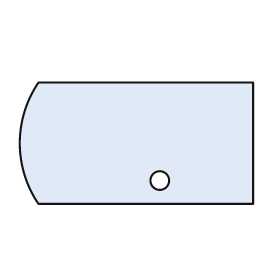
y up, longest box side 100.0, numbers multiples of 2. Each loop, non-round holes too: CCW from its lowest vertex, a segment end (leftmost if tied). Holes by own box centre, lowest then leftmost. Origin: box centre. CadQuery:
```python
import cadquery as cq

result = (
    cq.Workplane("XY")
    .moveTo(-42.0, -26.0)
    .lineTo(50.0, -26.0)
    .lineTo(50.0, 26.0)
    .lineTo(-42.0, 26.0)
    .threePointArc((-50.0, 0.0), (-42.0, -26.0))
    .close()
    .moveTo(10.0, -16.0)
    .circle(4.0)
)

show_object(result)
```